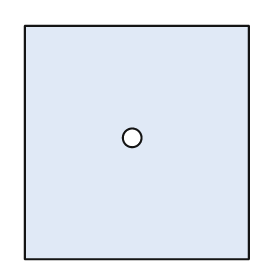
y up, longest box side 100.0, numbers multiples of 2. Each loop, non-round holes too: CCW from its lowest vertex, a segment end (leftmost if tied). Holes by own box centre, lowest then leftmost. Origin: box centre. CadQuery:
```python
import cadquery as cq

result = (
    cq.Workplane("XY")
    .moveTo(-48.0, -50.0)
    .lineTo(48.0, -50.0)
    .lineTo(48.0, 50.0)
    .lineTo(-48.0, 50.0)
    .close()
    .moveTo(-2.0, 2.0)
    .circle(4.0)
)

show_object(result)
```